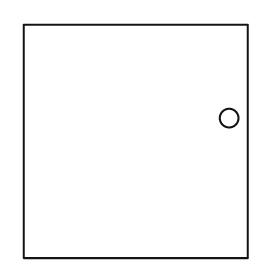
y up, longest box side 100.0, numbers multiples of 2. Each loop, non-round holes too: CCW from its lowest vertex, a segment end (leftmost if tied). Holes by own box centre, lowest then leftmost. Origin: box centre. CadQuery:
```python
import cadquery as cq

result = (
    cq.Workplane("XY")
    .moveTo(-48.0, -50.0)
    .lineTo(48.0, -50.0)
    .lineTo(48.0, 50.0)
    .lineTo(-48.0, 50.0)
    .close()
    .moveTo(40.0, 10.0)
    .circle(4.0)
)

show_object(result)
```